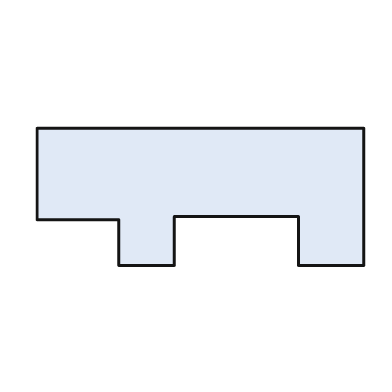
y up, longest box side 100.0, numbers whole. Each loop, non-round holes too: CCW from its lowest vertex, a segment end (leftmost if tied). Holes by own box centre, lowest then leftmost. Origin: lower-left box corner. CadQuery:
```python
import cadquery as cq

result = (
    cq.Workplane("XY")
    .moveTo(25.0, 0.0)
    .lineTo(42.0, 0.0)
    .lineTo(42.0, 15.0)
    .lineTo(80.0, 15.0)
    .lineTo(80.0, 0.0)
    .lineTo(100.0, 0.0)
    .lineTo(100.0, 42.0)
    .lineTo(0.0, 42.0)
    .lineTo(0.0, 14.0)
    .lineTo(25.0, 14.0)
    .close()
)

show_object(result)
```